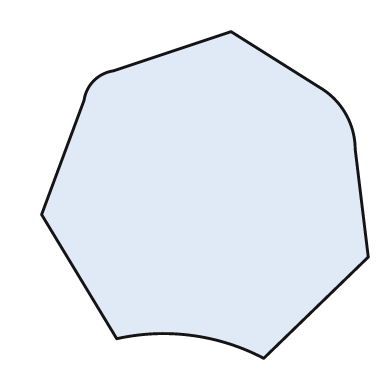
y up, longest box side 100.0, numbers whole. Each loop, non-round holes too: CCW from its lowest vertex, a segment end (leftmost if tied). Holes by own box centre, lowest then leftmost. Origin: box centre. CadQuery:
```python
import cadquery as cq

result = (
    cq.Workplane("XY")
    .moveTo(18.0, -50.0)
    .lineTo(50.0, -19.0)
    .lineTo(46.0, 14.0)
    .threePointArc((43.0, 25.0), (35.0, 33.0))
    .lineTo(8.0, 50.0)
    .lineTo(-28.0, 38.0)
    .threePointArc((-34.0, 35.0), (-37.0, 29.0))
    .lineTo(-50.0, -6.0)
    .lineTo(-27.0, -44.0)
    .threePointArc((-4.0, -43.0), (18.0, -50.0))
    .close()
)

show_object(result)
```